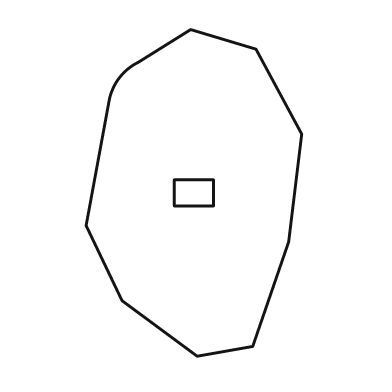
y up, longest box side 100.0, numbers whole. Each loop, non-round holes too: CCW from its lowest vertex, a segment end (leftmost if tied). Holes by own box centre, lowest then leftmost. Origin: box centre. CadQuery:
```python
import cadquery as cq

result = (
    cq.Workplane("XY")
    .moveTo(1.0, -50.0)
    .lineTo(18.0, -47.0)
    .lineTo(29.0, -15.0)
    .lineTo(33.0, 18.0)
    .lineTo(19.0, 44.0)
    .lineTo(-1.0, 50.0)
    .lineTo(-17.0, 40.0)
    .threePointArc((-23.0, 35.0), (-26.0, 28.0))
    .lineTo(-33.0, -10.0)
    .lineTo(-22.0, -33.0)
    .close()
    .moveTo(-6.0, -4.0)
    .lineTo(6.0, -4.0)
    .lineTo(6.0, 4.0)
    .lineTo(-6.0, 4.0)
    .close()
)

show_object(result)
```